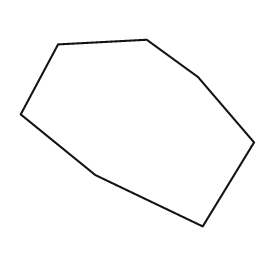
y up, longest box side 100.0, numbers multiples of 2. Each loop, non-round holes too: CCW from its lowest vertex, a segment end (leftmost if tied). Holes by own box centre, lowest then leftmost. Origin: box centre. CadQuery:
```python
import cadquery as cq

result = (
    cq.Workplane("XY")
    .moveTo(28.0, -40.0)
    .lineTo(50.0, -4.0)
    .lineTo(26.0, 24.0)
    .lineTo(4.0, 40.0)
    .lineTo(-34.0, 38.0)
    .lineTo(-50.0, 8.0)
    .lineTo(-18.0, -18.0)
    .close()
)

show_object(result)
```